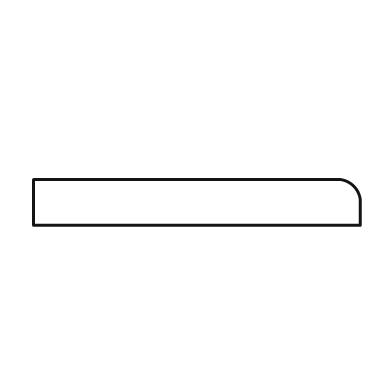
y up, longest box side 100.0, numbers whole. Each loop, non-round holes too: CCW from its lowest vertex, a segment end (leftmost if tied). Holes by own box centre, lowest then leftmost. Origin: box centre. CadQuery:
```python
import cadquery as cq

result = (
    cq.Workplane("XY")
    .moveTo(-50.0, -7.0)
    .lineTo(50.0, -7.0)
    .lineTo(50.0, 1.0)
    .threePointArc((48.0, 5.0), (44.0, 7.0))
    .lineTo(-50.0, 7.0)
    .close()
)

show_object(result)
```